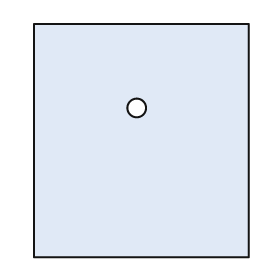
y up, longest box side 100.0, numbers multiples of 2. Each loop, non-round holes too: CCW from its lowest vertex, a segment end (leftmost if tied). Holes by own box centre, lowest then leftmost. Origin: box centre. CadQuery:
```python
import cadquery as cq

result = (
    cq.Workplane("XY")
    .moveTo(-46.0, -50.0)
    .lineTo(46.0, -50.0)
    .lineTo(46.0, 50.0)
    .lineTo(-46.0, 50.0)
    .close()
    .moveTo(-2.0, 14.0)
    .circle(4.0)
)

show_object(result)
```